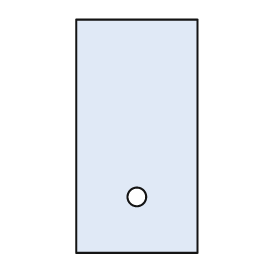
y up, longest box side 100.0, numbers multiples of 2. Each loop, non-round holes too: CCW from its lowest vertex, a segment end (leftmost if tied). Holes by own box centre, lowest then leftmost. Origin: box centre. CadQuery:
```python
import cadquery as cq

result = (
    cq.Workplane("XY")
    .moveTo(-26.0, -50.0)
    .lineTo(26.0, -50.0)
    .lineTo(26.0, 50.0)
    .lineTo(-26.0, 50.0)
    .close()
    .moveTo(0.0, -26.0)
    .circle(4.0)
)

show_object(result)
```